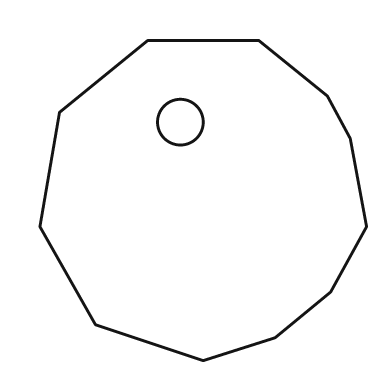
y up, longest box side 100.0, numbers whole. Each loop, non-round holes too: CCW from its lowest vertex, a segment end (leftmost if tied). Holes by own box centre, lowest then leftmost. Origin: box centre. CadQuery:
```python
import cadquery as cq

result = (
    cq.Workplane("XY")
    .moveTo(0.0, -49.0)
    .lineTo(22.0, -42.0)
    .lineTo(39.0, -28.0)
    .lineTo(50.0, -8.0)
    .lineTo(45.0, 19.0)
    .lineTo(38.0, 32.0)
    .lineTo(17.0, 49.0)
    .lineTo(-17.0, 49.0)
    .lineTo(-44.0, 27.0)
    .lineTo(-50.0, -8.0)
    .lineTo(-33.0, -38.0)
    .close()
    .moveTo(-7.0, 24.0)
    .circle(7.0)
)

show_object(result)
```